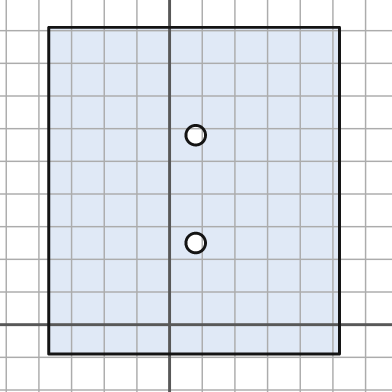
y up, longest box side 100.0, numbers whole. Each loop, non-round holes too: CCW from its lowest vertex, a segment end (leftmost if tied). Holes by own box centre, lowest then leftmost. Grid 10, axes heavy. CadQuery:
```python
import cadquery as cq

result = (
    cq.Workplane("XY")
    .moveTo(-37.0, -9.0)
    .lineTo(52.0, -9.0)
    .lineTo(52.0, 91.0)
    .lineTo(-37.0, 91.0)
    .close()
    .moveTo(8.0, 25.0)
    .circle(3.0)
    .moveTo(8.0, 58.0)
    .circle(3.0)
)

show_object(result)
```